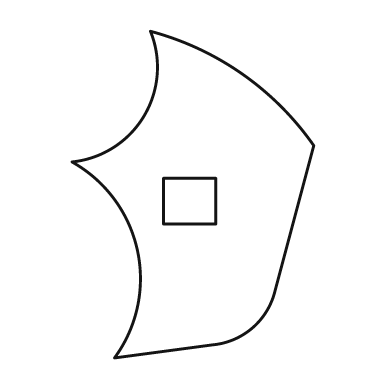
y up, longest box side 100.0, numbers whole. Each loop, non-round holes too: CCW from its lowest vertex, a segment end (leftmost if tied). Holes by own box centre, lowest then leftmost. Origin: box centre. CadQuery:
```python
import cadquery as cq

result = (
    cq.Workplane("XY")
    .moveTo(-24.0, -50.0)
    .lineTo(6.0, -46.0)
    .threePointArc((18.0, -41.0), (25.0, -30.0))
    .lineTo(37.0, 15.0)
    .threePointArc((15.0, 37.0), (-13.0, 50.0))
    .threePointArc((-15.0, 24.0), (-37.0, 10.0))
    .threePointArc((-17.0, -17.0), (-24.0, -50.0))
    .close()
    .moveTo(-9.0, -9.0)
    .lineTo(7.0, -9.0)
    .lineTo(7.0, 5.0)
    .lineTo(-9.0, 5.0)
    .close()
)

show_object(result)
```